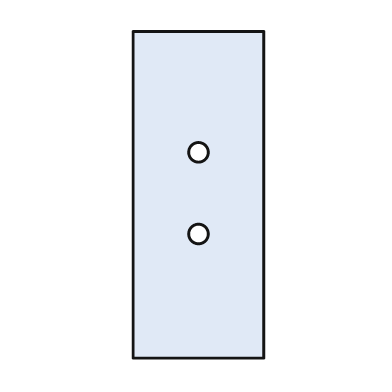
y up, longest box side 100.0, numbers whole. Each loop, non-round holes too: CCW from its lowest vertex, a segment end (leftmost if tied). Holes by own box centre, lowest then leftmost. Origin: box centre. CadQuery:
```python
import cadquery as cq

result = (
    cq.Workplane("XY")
    .moveTo(-20.0, -50.0)
    .lineTo(20.0, -50.0)
    .lineTo(20.0, 50.0)
    .lineTo(-20.0, 50.0)
    .close()
    .moveTo(0.0, -12.0)
    .circle(3.0)
    .moveTo(0.0, 13.0)
    .circle(3.0)
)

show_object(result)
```